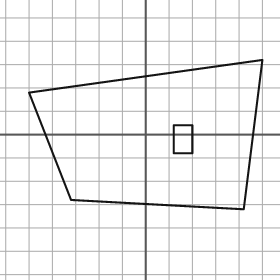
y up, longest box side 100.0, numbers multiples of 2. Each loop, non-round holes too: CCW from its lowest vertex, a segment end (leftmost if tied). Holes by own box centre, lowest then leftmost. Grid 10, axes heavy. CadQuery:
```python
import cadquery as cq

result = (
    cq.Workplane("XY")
    .moveTo(42.0, -32.0)
    .lineTo(50.0, 32.0)
    .lineTo(-50.0, 18.0)
    .lineTo(-32.0, -28.0)
    .close()
    .moveTo(12.0, -8.0)
    .lineTo(20.0, -8.0)
    .lineTo(20.0, 4.0)
    .lineTo(12.0, 4.0)
    .close()
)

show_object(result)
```